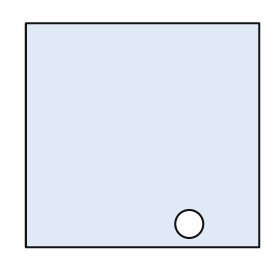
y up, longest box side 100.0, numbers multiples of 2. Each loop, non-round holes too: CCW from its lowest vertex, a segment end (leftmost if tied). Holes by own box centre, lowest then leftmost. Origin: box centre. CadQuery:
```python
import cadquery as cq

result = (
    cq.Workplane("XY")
    .moveTo(-50.0, -48.0)
    .lineTo(50.0, -48.0)
    .lineTo(50.0, 48.0)
    .lineTo(-50.0, 48.0)
    .close()
    .moveTo(20.0, -38.0)
    .circle(6.0)
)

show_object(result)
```